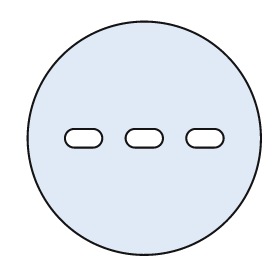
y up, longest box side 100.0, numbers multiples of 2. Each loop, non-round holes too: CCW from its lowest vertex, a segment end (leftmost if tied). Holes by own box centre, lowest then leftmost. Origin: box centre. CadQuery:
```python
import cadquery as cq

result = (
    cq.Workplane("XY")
    .moveTo(0.0, 0.0)
    .circle(50.0)
    .moveTo(-30.0, -4.0)
    .lineTo(-22.0, -4.0)
    .threePointArc((-18.0, 0.0), (-22.0, 4.0))
    .lineTo(-30.0, 4.0)
    .threePointArc((-34.0, 0.0), (-30.0, -4.0))
    .close()
    .moveTo(-4.0, -4.0)
    .lineTo(4.0, -4.0)
    .threePointArc((8.0, 0.0), (4.0, 4.0))
    .lineTo(-4.0, 4.0)
    .threePointArc((-8.0, 0.0), (-4.0, -4.0))
    .close()
    .moveTo(22.0, -4.0)
    .lineTo(30.0, -4.0)
    .threePointArc((34.0, 0.0), (30.0, 4.0))
    .lineTo(22.0, 4.0)
    .threePointArc((18.0, 0.0), (22.0, -4.0))
    .close()
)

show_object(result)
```